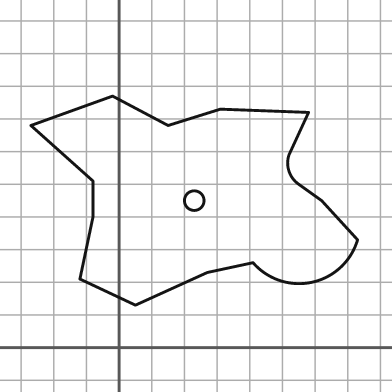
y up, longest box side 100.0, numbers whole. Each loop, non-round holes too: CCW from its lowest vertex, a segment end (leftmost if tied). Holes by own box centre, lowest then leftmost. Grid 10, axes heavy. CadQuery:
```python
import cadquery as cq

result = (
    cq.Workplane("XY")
    .moveTo(5.0, 13.0)
    .lineTo(27.0, 23.0)
    .lineTo(41.0, 26.0)
    .threePointArc((59.0, 20.0), (73.0, 33.0))
    .lineTo(62.0, 45.0)
    .lineTo(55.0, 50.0)
    .threePointArc((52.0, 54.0), (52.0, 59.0))
    .lineTo(58.0, 72.0)
    .lineTo(31.0, 73.0)
    .lineTo(15.0, 68.0)
    .lineTo(-2.0, 77.0)
    .lineTo(-27.0, 68.0)
    .lineTo(-8.0, 51.0)
    .lineTo(-8.0, 40.0)
    .lineTo(-12.0, 21.0)
    .close()
    .moveTo(23.0, 45.0)
    .circle(3.0)
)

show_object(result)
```